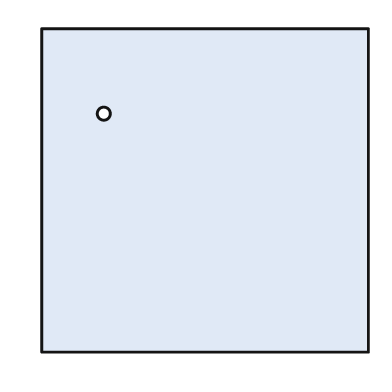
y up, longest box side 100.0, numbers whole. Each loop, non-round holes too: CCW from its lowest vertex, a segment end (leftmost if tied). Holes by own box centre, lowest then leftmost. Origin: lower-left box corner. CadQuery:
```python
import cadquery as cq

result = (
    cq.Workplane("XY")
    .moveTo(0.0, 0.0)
    .lineTo(100.0, 0.0)
    .lineTo(100.0, 99.0)
    .lineTo(0.0, 99.0)
    .close()
    .moveTo(19.0, 73.0)
    .circle(2.0)
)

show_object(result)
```